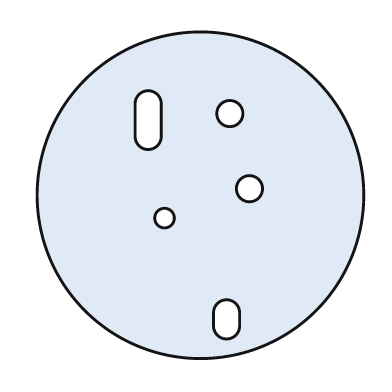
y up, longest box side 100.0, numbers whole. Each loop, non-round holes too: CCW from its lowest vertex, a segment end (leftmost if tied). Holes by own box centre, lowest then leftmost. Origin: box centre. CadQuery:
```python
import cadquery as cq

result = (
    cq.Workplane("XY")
    .moveTo(0.0, 0.0)
    .circle(50.0)
    .moveTo(4.0, -40.0)
    .threePointArc((8.0, -44.0), (12.0, -40.0))
    .lineTo(12.0, -36.0)
    .threePointArc((8.0, -32.0), (4.0, -36.0))
    .close()
    .moveTo(-11.0, -7.0)
    .circle(3.0)
    .moveTo(15.0, 2.0)
    .circle(4.0)
    .moveTo(-20.0, 18.0)
    .threePointArc((-16.0, 14.0), (-12.0, 18.0))
    .lineTo(-12.0, 28.0)
    .threePointArc((-16.0, 32.0), (-20.0, 28.0))
    .close()
    .moveTo(9.0, 25.0)
    .circle(4.0)
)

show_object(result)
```